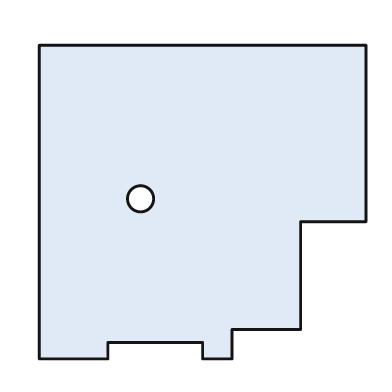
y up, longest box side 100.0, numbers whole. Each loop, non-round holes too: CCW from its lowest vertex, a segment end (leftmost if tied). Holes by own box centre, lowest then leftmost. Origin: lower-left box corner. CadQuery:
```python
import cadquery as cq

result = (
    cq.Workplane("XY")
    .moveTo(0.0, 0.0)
    .lineTo(21.0, 0.0)
    .lineTo(21.0, 5.0)
    .lineTo(50.0, 5.0)
    .lineTo(50.0, 0.0)
    .lineTo(59.0, 0.0)
    .lineTo(59.0, 9.0)
    .lineTo(80.0, 9.0)
    .lineTo(80.0, 42.0)
    .lineTo(100.0, 42.0)
    .lineTo(100.0, 96.0)
    .lineTo(0.0, 96.0)
    .close()
    .moveTo(31.0, 49.0)
    .circle(4.0)
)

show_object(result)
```